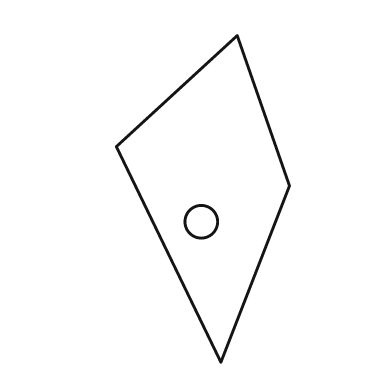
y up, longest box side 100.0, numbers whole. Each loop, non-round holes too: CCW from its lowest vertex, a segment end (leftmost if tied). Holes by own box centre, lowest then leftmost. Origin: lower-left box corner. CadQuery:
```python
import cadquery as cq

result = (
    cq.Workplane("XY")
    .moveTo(32.0, 0.0)
    .lineTo(53.0, 54.0)
    .lineTo(37.0, 100.0)
    .lineTo(0.0, 66.0)
    .close()
    .moveTo(26.0, 43.0)
    .circle(5.0)
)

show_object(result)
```